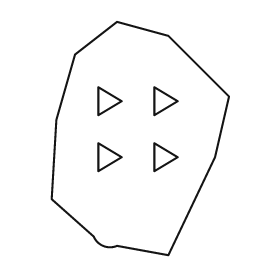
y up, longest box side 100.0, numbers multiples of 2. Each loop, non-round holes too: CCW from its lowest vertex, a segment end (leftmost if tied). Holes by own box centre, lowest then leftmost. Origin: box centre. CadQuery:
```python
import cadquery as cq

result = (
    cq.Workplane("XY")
    .moveTo(12.0, -50.0)
    .lineTo(32.0, -8.0)
    .lineTo(38.0, 18.0)
    .lineTo(12.0, 44.0)
    .lineTo(-10.0, 50.0)
    .lineTo(-28.0, 36.0)
    .lineTo(-36.0, 8.0)
    .lineTo(-38.0, -26.0)
    .lineTo(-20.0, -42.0)
    .threePointArc((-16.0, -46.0), (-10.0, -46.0))
    .close()
    .moveTo(-18.0, -14.0)
    .lineTo(-8.0, -8.0)
    .lineTo(-18.0, -2.0)
    .close()
    .moveTo(6.0, -14.0)
    .lineTo(16.0, -8.0)
    .lineTo(6.0, -2.0)
    .close()
    .moveTo(-18.0, 10.0)
    .lineTo(-8.0, 16.0)
    .lineTo(-18.0, 22.0)
    .close()
    .moveTo(6.0, 10.0)
    .lineTo(16.0, 16.0)
    .lineTo(6.0, 22.0)
    .close()
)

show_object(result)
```